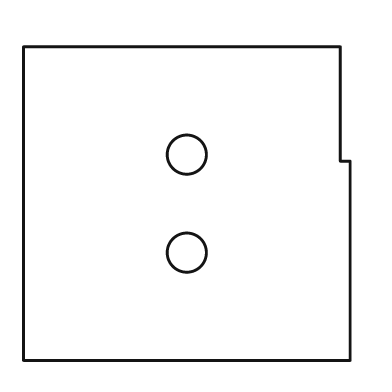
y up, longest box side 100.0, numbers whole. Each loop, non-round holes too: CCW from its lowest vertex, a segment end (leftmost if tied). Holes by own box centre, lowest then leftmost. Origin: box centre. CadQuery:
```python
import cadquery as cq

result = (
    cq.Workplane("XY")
    .moveTo(-50.0, -48.0)
    .lineTo(50.0, -48.0)
    .lineTo(50.0, 13.0)
    .lineTo(47.0, 13.0)
    .lineTo(47.0, 48.0)
    .lineTo(-50.0, 48.0)
    .close()
    .moveTo(0.0, -15.0)
    .circle(6.0)
    .moveTo(0.0, 15.0)
    .circle(6.0)
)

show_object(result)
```